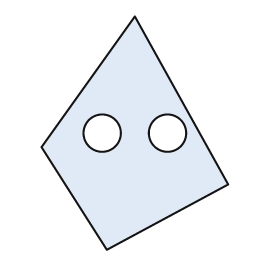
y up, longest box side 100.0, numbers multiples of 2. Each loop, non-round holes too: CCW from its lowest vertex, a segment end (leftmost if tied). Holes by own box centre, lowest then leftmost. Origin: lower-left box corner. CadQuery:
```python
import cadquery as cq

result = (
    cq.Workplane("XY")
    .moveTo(28.0, 0.0)
    .lineTo(80.0, 28.0)
    .lineTo(40.0, 100.0)
    .lineTo(0.0, 44.0)
    .close()
    .moveTo(26.0, 50.0)
    .circle(8.0)
    .moveTo(54.0, 50.0)
    .circle(8.0)
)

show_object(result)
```